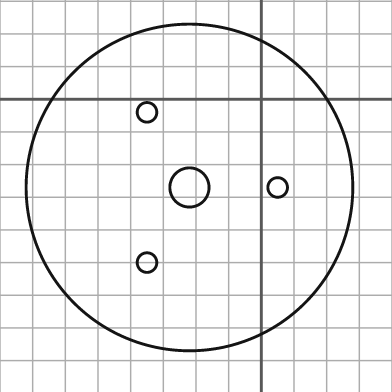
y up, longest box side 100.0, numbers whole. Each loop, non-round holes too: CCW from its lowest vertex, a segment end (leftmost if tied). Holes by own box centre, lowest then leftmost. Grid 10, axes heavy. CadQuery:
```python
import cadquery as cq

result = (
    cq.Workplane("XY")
    .moveTo(-22.0, -27.0)
    .circle(50.0)
    .moveTo(-35.0, -50.0)
    .circle(3.0)
    .moveTo(-22.0, -27.0)
    .circle(6.0)
    .moveTo(5.0, -27.0)
    .circle(3.0)
    .moveTo(-35.0, -4.0)
    .circle(3.0)
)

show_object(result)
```